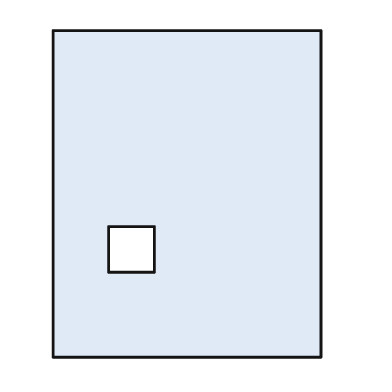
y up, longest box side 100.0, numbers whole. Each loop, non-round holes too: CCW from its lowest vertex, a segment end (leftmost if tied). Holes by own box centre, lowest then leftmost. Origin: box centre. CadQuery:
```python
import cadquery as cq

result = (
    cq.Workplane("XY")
    .moveTo(-41.0, -50.0)
    .lineTo(41.0, -50.0)
    .lineTo(41.0, 50.0)
    .lineTo(-41.0, 50.0)
    .close()
    .moveTo(-24.0, -24.0)
    .lineTo(-10.0, -24.0)
    .lineTo(-10.0, -10.0)
    .lineTo(-24.0, -10.0)
    .close()
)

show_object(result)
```